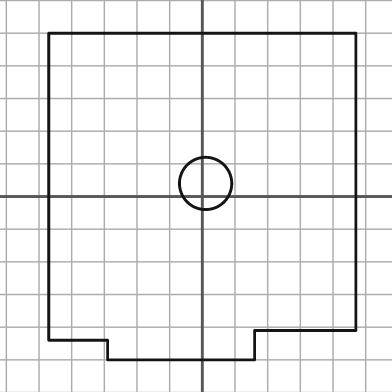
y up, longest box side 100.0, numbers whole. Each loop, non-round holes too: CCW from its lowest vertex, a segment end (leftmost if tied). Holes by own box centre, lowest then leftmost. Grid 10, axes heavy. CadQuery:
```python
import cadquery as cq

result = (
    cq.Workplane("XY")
    .moveTo(-29.0, -50.0)
    .lineTo(16.0, -50.0)
    .lineTo(16.0, -41.0)
    .lineTo(47.0, -41.0)
    .lineTo(47.0, 50.0)
    .lineTo(-47.0, 50.0)
    .lineTo(-47.0, -44.0)
    .lineTo(-29.0, -44.0)
    .close()
    .moveTo(1.0, 4.0)
    .circle(8.0)
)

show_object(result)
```